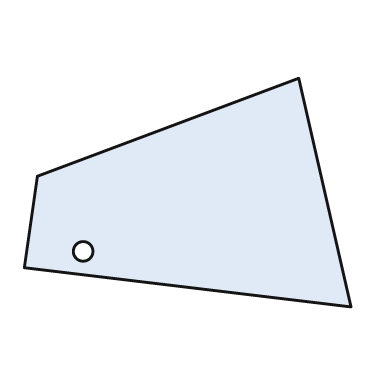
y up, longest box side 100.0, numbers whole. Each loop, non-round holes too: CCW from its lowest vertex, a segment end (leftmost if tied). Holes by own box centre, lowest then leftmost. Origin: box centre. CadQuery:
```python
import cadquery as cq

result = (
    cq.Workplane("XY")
    .moveTo(50.0, -35.0)
    .lineTo(34.0, 35.0)
    .lineTo(-46.0, 5.0)
    .lineTo(-50.0, -23.0)
    .close()
    .moveTo(-32.0, -18.0)
    .circle(3.0)
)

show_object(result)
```